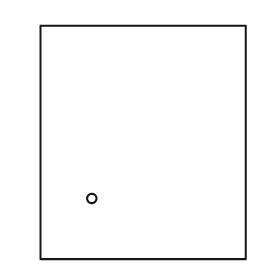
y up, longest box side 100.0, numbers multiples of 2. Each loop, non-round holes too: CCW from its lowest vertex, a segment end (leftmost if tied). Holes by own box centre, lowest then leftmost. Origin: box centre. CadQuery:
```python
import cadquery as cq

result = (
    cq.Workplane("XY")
    .moveTo(-44.0, -50.0)
    .lineTo(44.0, -50.0)
    .lineTo(44.0, 50.0)
    .lineTo(-44.0, 50.0)
    .close()
    .moveTo(-22.0, -24.0)
    .circle(2.0)
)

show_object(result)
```